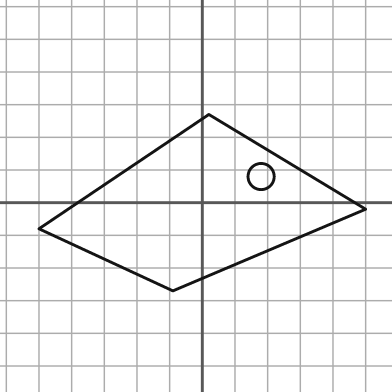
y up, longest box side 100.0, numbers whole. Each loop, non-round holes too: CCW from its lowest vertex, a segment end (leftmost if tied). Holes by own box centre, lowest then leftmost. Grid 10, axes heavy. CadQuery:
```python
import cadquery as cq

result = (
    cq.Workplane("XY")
    .moveTo(-9.0, -27.0)
    .lineTo(50.0, -2.0)
    .lineTo(2.0, 27.0)
    .lineTo(-50.0, -8.0)
    .close()
    .moveTo(18.0, 8.0)
    .circle(4.0)
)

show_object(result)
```